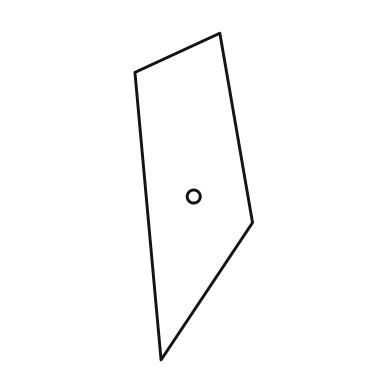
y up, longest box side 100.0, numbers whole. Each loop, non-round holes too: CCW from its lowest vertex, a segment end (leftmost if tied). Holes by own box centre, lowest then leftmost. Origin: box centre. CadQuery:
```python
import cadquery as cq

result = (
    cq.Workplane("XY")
    .moveTo(-10.0, -50.0)
    .lineTo(18.0, -8.0)
    .lineTo(8.0, 50.0)
    .lineTo(-18.0, 38.0)
    .close()
    .moveTo(0.0, 0.0)
    .circle(2.0)
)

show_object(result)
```